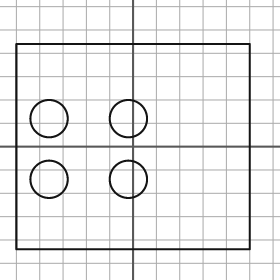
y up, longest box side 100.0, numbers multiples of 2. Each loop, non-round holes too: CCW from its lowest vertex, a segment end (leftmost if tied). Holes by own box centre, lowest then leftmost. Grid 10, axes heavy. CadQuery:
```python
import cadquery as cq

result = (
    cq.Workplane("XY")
    .moveTo(-50.0, -44.0)
    .lineTo(50.0, -44.0)
    .lineTo(50.0, 44.0)
    .lineTo(-50.0, 44.0)
    .close()
    .moveTo(-36.0, -14.0)
    .circle(8.0)
    .moveTo(-2.0, -14.0)
    .circle(8.0)
    .moveTo(-36.0, 12.0)
    .circle(8.0)
    .moveTo(-2.0, 12.0)
    .circle(8.0)
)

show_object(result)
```